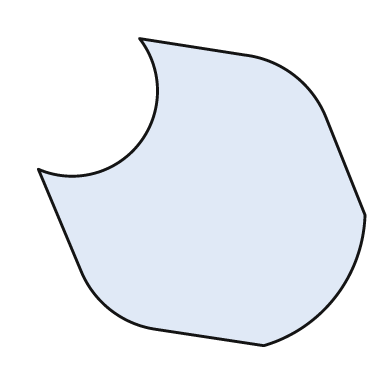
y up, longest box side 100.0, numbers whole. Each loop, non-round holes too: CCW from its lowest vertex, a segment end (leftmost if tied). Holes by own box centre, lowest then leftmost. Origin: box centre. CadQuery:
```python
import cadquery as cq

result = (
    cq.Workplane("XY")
    .moveTo(19.0, -47.0)
    .threePointArc((41.0, -32.0), (50.0, -7.0))
    .lineTo(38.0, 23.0)
    .threePointArc((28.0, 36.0), (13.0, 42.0))
    .lineTo(-19.0, 47.0)
    .threePointArc((-19.0, 15.0), (-50.0, 7.0))
    .lineTo(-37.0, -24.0)
    .threePointArc((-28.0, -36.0), (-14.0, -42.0))
    .close()
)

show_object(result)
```